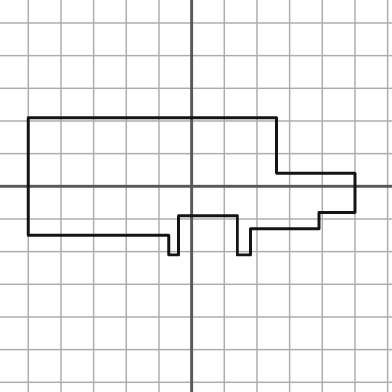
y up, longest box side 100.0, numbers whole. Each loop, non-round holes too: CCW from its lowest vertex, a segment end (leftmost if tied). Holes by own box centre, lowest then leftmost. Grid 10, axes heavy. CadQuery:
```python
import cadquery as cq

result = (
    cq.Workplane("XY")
    .moveTo(-7.0, -21.0)
    .lineTo(-4.0, -21.0)
    .lineTo(-4.0, -9.0)
    .lineTo(14.0, -9.0)
    .lineTo(14.0, -21.0)
    .lineTo(18.0, -21.0)
    .lineTo(18.0, -13.0)
    .lineTo(39.0, -13.0)
    .lineTo(39.0, -8.0)
    .lineTo(50.0, -8.0)
    .lineTo(50.0, 4.0)
    .lineTo(26.0, 4.0)
    .lineTo(26.0, 21.0)
    .lineTo(-50.0, 21.0)
    .lineTo(-50.0, -15.0)
    .lineTo(-7.0, -15.0)
    .close()
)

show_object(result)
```